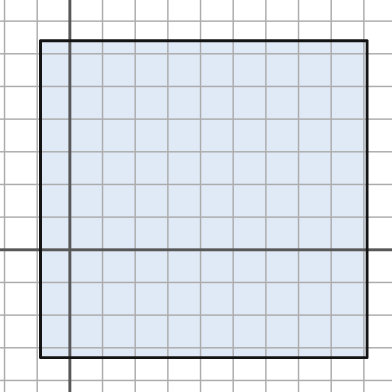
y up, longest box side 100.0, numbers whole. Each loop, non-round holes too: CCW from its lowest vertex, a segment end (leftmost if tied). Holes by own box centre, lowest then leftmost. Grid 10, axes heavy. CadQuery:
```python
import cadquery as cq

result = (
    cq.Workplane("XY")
    .moveTo(-9.0, -33.0)
    .lineTo(91.0, -33.0)
    .lineTo(91.0, 64.0)
    .lineTo(-9.0, 64.0)
    .close()
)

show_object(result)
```